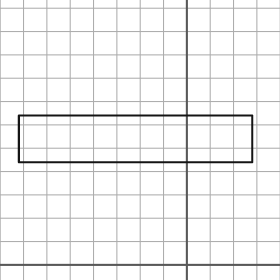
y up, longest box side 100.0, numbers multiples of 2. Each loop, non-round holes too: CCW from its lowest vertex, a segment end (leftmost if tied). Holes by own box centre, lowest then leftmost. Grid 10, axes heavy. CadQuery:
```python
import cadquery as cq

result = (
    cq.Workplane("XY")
    .moveTo(-72.0, 44.0)
    .lineTo(28.0, 44.0)
    .lineTo(28.0, 64.0)
    .lineTo(-72.0, 64.0)
    .close()
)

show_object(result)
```